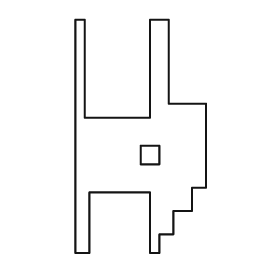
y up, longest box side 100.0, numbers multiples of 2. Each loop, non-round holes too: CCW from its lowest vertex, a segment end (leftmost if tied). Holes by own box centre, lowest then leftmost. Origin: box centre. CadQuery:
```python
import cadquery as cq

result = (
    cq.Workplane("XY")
    .moveTo(-28.0, -50.0)
    .lineTo(-22.0, -50.0)
    .lineTo(-22.0, -24.0)
    .lineTo(4.0, -24.0)
    .lineTo(4.0, -50.0)
    .lineTo(8.0, -50.0)
    .lineTo(8.0, -42.0)
    .lineTo(14.0, -42.0)
    .lineTo(14.0, -32.0)
    .lineTo(22.0, -32.0)
    .lineTo(22.0, -22.0)
    .lineTo(28.0, -22.0)
    .lineTo(28.0, 14.0)
    .lineTo(12.0, 14.0)
    .lineTo(12.0, 50.0)
    .lineTo(4.0, 50.0)
    .lineTo(4.0, 8.0)
    .lineTo(-24.0, 8.0)
    .lineTo(-24.0, 50.0)
    .lineTo(-28.0, 50.0)
    .close()
    .moveTo(0.0, -12.0)
    .lineTo(8.0, -12.0)
    .lineTo(8.0, -4.0)
    .lineTo(0.0, -4.0)
    .close()
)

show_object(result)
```